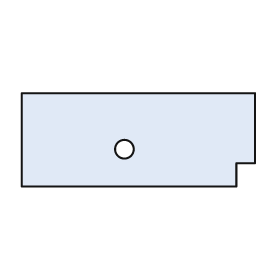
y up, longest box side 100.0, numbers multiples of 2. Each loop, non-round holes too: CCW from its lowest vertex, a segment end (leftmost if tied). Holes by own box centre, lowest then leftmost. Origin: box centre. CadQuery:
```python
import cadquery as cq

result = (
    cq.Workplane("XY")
    .moveTo(-50.0, -20.0)
    .lineTo(42.0, -20.0)
    .lineTo(42.0, -10.0)
    .lineTo(50.0, -10.0)
    .lineTo(50.0, 20.0)
    .lineTo(-50.0, 20.0)
    .close()
    .moveTo(-6.0, -4.0)
    .circle(4.0)
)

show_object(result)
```